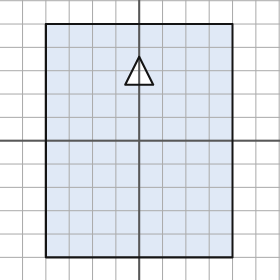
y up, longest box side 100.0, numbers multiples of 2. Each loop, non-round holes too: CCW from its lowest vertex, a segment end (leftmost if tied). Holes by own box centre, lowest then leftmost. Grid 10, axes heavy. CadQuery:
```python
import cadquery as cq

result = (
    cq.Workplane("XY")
    .moveTo(-40.0, -50.0)
    .lineTo(40.0, -50.0)
    .lineTo(40.0, 50.0)
    .lineTo(-40.0, 50.0)
    .close()
    .moveTo(-6.0, 24.0)
    .lineTo(6.0, 24.0)
    .lineTo(0.0, 36.0)
    .close()
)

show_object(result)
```